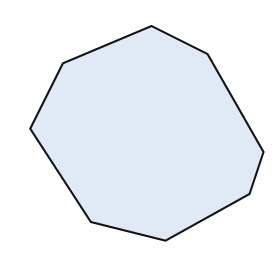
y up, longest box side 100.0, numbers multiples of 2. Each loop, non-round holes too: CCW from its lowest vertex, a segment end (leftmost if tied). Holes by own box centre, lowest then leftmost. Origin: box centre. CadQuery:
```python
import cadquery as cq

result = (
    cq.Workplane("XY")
    .moveTo(8.0, -46.0)
    .lineTo(44.0, -26.0)
    .lineTo(50.0, -8.0)
    .lineTo(26.0, 34.0)
    .lineTo(2.0, 46.0)
    .lineTo(-36.0, 30.0)
    .lineTo(-50.0, 2.0)
    .lineTo(-24.0, -38.0)
    .close()
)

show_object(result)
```